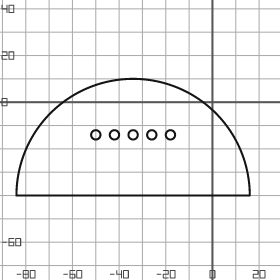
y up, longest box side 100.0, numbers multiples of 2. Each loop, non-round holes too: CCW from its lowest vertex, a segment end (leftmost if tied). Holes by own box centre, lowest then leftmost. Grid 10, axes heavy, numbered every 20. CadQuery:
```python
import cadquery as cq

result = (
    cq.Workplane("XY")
    .moveTo(-84.0, -40.0)
    .lineTo(16.0, -40.0)
    .threePointArc((-34.0, 10.0), (-84.0, -40.0))
    .close()
    .moveTo(-50.0, -14.0)
    .circle(2.0)
    .moveTo(-42.0, -14.0)
    .circle(2.0)
    .moveTo(-34.0, -14.0)
    .circle(2.0)
    .moveTo(-26.0, -14.0)
    .circle(2.0)
    .moveTo(-18.0, -14.0)
    .circle(2.0)
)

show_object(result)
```